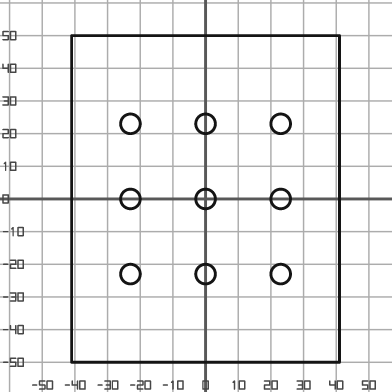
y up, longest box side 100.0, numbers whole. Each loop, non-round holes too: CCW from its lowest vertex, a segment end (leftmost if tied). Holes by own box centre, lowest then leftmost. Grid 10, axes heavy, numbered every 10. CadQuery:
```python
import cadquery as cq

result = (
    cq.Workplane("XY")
    .moveTo(-41.0, -50.0)
    .lineTo(41.0, -50.0)
    .lineTo(41.0, 50.0)
    .lineTo(-41.0, 50.0)
    .close()
    .moveTo(-23.0, -23.0)
    .circle(3.0)
    .moveTo(0.0, -23.0)
    .circle(3.0)
    .moveTo(23.0, -23.0)
    .circle(3.0)
    .moveTo(-23.0, 0.0)
    .circle(3.0)
    .moveTo(0.0, 0.0)
    .circle(3.0)
    .moveTo(23.0, 0.0)
    .circle(3.0)
    .moveTo(-23.0, 23.0)
    .circle(3.0)
    .moveTo(0.0, 23.0)
    .circle(3.0)
    .moveTo(23.0, 23.0)
    .circle(3.0)
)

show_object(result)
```